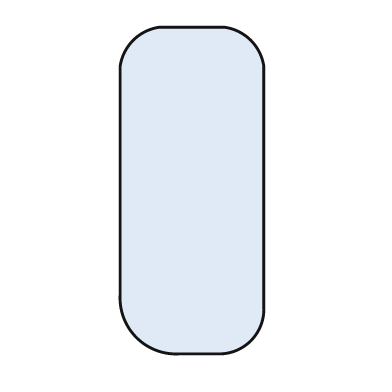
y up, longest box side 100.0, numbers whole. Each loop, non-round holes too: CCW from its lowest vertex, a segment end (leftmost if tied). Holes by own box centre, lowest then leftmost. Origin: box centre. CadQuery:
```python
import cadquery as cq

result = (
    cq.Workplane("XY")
    .moveTo(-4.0, -50.0)
    .lineTo(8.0, -50.0)
    .threePointArc((18.0, -46.0), (22.0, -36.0))
    .lineTo(22.0, 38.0)
    .threePointArc((18.0, 46.0), (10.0, 50.0))
    .lineTo(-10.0, 50.0)
    .threePointArc((-18.0, 46.0), (-22.0, 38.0))
    .lineTo(-22.0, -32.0)
    .threePointArc((-17.0, -45.0), (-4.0, -50.0))
    .close()
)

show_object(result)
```